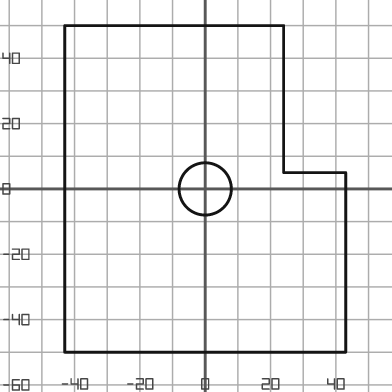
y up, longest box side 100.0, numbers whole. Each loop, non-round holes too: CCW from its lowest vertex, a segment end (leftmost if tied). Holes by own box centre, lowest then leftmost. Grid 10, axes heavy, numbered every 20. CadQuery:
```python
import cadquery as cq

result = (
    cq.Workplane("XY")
    .moveTo(-43.0, -50.0)
    .lineTo(43.0, -50.0)
    .lineTo(43.0, 5.0)
    .lineTo(24.0, 5.0)
    .lineTo(24.0, 50.0)
    .lineTo(-43.0, 50.0)
    .close()
    .moveTo(0.0, 0.0)
    .circle(8.0)
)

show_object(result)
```